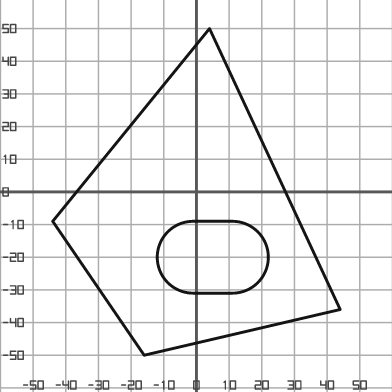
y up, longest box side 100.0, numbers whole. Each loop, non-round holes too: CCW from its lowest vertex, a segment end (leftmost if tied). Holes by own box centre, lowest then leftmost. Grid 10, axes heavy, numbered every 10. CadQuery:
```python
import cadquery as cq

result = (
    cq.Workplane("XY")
    .moveTo(-16.0, -50.0)
    .lineTo(44.0, -36.0)
    .lineTo(4.0, 50.0)
    .lineTo(-44.0, -9.0)
    .close()
    .moveTo(-1.0, -31.0)
    .lineTo(11.0, -31.0)
    .threePointArc((22.0, -20.0), (11.0, -9.0))
    .lineTo(-1.0, -9.0)
    .threePointArc((-12.0, -20.0), (-1.0, -31.0))
    .close()
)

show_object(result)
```